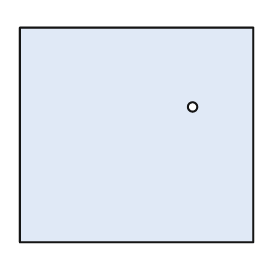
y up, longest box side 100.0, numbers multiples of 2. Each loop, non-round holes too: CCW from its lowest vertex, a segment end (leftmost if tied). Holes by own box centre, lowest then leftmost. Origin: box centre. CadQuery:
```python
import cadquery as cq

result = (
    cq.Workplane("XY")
    .moveTo(-50.0, -46.0)
    .lineTo(50.0, -46.0)
    .lineTo(50.0, 46.0)
    .lineTo(-50.0, 46.0)
    .close()
    .moveTo(24.0, 12.0)
    .circle(2.0)
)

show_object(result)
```